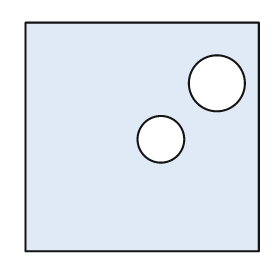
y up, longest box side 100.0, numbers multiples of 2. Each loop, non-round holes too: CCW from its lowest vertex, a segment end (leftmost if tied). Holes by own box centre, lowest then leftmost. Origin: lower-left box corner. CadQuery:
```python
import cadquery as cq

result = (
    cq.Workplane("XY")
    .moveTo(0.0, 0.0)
    .lineTo(100.0, 0.0)
    .lineTo(100.0, 98.0)
    .lineTo(0.0, 98.0)
    .close()
    .moveTo(58.0, 48.0)
    .circle(10.0)
    .moveTo(82.0, 72.0)
    .circle(12.0)
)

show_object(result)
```